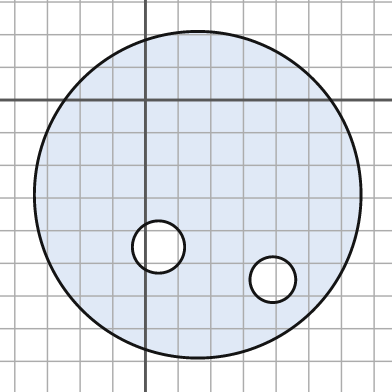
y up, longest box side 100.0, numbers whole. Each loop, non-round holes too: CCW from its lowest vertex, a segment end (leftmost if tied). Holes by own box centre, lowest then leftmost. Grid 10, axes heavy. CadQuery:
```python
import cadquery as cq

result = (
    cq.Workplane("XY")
    .moveTo(16.0, -29.0)
    .circle(50.0)
    .moveTo(39.0, -55.0)
    .circle(7.0)
    .moveTo(4.0, -45.0)
    .circle(8.0)
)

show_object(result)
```